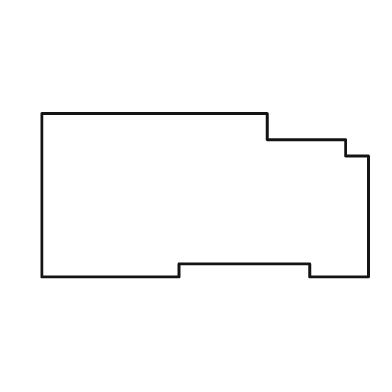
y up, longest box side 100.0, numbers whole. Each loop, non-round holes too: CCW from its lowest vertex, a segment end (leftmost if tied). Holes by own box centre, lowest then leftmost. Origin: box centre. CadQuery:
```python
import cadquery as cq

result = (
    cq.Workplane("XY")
    .moveTo(-50.0, -25.0)
    .lineTo(-8.0, -25.0)
    .lineTo(-8.0, -21.0)
    .lineTo(32.0, -21.0)
    .lineTo(32.0, -25.0)
    .lineTo(50.0, -25.0)
    .lineTo(50.0, 12.0)
    .lineTo(43.0, 12.0)
    .lineTo(43.0, 17.0)
    .lineTo(19.0, 17.0)
    .lineTo(19.0, 25.0)
    .lineTo(-50.0, 25.0)
    .close()
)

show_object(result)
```